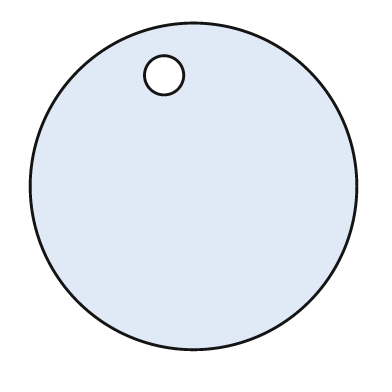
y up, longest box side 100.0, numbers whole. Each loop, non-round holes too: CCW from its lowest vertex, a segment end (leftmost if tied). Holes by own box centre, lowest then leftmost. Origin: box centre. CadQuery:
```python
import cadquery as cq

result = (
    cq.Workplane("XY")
    .moveTo(0.0, 0.0)
    .circle(50.0)
    .moveTo(-9.0, 34.0)
    .circle(6.0)
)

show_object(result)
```